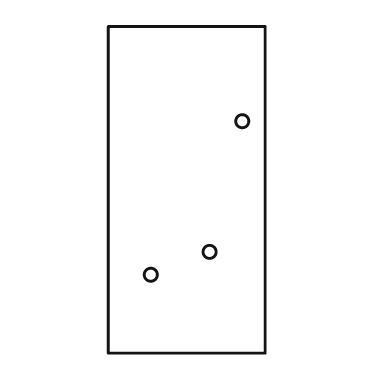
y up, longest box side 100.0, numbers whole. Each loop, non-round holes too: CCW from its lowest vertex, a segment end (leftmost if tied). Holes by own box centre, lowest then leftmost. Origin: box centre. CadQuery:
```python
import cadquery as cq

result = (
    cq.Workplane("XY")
    .moveTo(-24.0, -50.0)
    .lineTo(24.0, -50.0)
    .lineTo(24.0, 50.0)
    .lineTo(-24.0, 50.0)
    .close()
    .moveTo(-11.0, -26.0)
    .circle(2.0)
    .moveTo(7.0, -19.0)
    .circle(2.0)
    .moveTo(17.0, 21.0)
    .circle(2.0)
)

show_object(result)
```